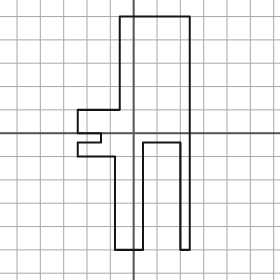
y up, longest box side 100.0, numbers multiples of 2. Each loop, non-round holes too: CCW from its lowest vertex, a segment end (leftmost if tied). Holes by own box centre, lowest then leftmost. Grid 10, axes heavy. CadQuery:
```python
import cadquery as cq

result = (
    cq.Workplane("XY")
    .moveTo(-8.0, -50.0)
    .lineTo(4.0, -50.0)
    .lineTo(4.0, -4.0)
    .lineTo(20.0, -4.0)
    .lineTo(20.0, -50.0)
    .lineTo(24.0, -50.0)
    .lineTo(24.0, 50.0)
    .lineTo(-6.0, 50.0)
    .lineTo(-6.0, 10.0)
    .lineTo(-24.0, 10.0)
    .lineTo(-24.0, 0.0)
    .lineTo(-14.0, 0.0)
    .lineTo(-14.0, -4.0)
    .lineTo(-24.0, -4.0)
    .lineTo(-24.0, -10.0)
    .lineTo(-8.0, -10.0)
    .close()
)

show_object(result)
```